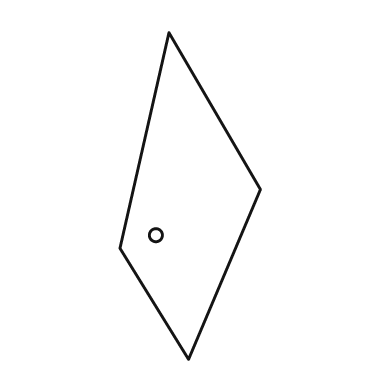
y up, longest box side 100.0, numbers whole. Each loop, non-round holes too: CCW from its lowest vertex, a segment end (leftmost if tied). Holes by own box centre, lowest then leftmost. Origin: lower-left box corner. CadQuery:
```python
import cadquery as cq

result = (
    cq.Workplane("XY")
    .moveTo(21.0, 0.0)
    .lineTo(43.0, 52.0)
    .lineTo(15.0, 100.0)
    .lineTo(0.0, 34.0)
    .close()
    .moveTo(11.0, 38.0)
    .circle(2.0)
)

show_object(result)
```